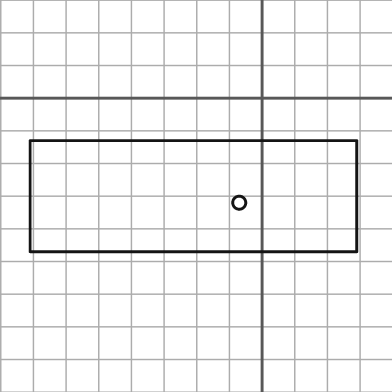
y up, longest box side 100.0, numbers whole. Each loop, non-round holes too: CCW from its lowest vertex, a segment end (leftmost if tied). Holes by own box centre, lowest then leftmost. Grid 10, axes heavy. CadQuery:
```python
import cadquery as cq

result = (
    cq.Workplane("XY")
    .moveTo(-71.0, -47.0)
    .lineTo(29.0, -47.0)
    .lineTo(29.0, -13.0)
    .lineTo(-71.0, -13.0)
    .close()
    .moveTo(-7.0, -32.0)
    .circle(2.0)
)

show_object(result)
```